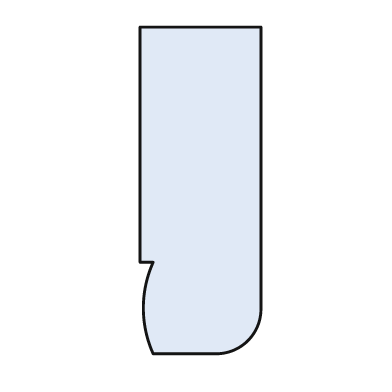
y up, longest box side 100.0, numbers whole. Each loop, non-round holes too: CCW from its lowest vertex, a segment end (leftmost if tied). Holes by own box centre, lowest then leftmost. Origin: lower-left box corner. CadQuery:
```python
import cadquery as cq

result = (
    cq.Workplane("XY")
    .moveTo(4.0, 0.0)
    .lineTo(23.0, 0.0)
    .threePointArc((33.0, 4.0), (37.0, 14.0))
    .lineTo(37.0, 100.0)
    .lineTo(0.0, 100.0)
    .lineTo(0.0, 28.0)
    .lineTo(4.0, 28.0)
    .threePointArc((1.0, 14.0), (4.0, 0.0))
    .close()
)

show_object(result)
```